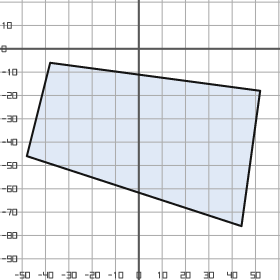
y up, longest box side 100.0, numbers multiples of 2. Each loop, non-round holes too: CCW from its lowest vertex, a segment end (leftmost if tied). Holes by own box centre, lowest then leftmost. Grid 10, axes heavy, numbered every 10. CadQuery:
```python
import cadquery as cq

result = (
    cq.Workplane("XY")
    .moveTo(44.0, -76.0)
    .lineTo(52.0, -18.0)
    .lineTo(-38.0, -6.0)
    .lineTo(-48.0, -46.0)
    .close()
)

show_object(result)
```